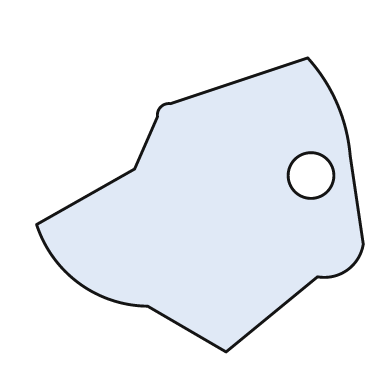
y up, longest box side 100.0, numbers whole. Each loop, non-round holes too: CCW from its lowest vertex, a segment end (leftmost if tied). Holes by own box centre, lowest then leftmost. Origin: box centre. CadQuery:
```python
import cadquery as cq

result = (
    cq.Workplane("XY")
    .moveTo(8.0, -45.0)
    .lineTo(36.0, -22.0)
    .threePointArc((45.0, -20.0), (50.0, -12.0))
    .lineTo(46.0, 15.0)
    .threePointArc((42.0, 31.0), (33.0, 45.0))
    .lineTo(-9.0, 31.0)
    .threePointArc((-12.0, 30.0), (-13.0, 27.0))
    .lineTo(-20.0, 11.0)
    .lineTo(-50.0, -6.0)
    .threePointArc((-37.0, -24.0), (-16.0, -31.0))
    .close()
    .moveTo(34.0, 9.0)
    .circle(7.0)
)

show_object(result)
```